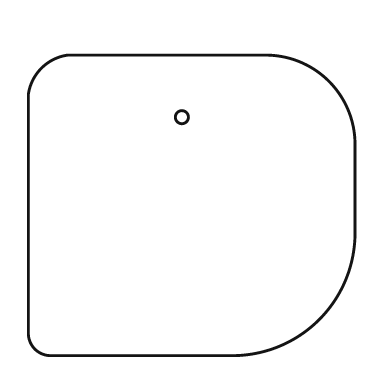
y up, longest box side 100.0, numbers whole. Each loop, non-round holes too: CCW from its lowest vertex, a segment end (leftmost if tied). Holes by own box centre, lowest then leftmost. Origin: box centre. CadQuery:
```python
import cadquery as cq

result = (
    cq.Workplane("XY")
    .moveTo(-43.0, -46.0)
    .lineTo(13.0, -46.0)
    .threePointArc((39.0, -35.0), (50.0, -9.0))
    .lineTo(50.0, 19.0)
    .threePointArc((42.0, 38.0), (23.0, 46.0))
    .lineTo(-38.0, 46.0)
    .threePointArc((-46.0, 42.0), (-50.0, 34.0))
    .lineTo(-50.0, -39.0)
    .threePointArc((-48.0, -44.0), (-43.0, -46.0))
    .close()
    .moveTo(-3.0, 27.0)
    .circle(2.0)
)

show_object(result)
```